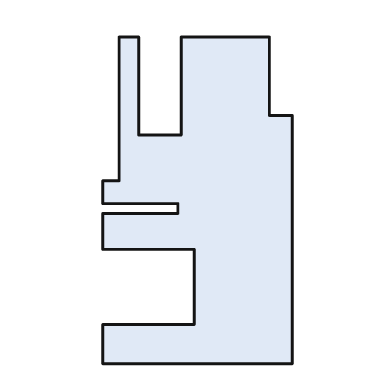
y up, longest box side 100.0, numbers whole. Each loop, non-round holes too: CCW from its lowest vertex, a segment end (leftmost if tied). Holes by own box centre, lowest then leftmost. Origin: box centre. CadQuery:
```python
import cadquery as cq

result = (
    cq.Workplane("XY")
    .moveTo(-29.0, -50.0)
    .lineTo(29.0, -50.0)
    .lineTo(29.0, 26.0)
    .lineTo(22.0, 26.0)
    .lineTo(22.0, 50.0)
    .lineTo(-5.0, 50.0)
    .lineTo(-5.0, 20.0)
    .lineTo(-18.0, 20.0)
    .lineTo(-18.0, 50.0)
    .lineTo(-24.0, 50.0)
    .lineTo(-24.0, 6.0)
    .lineTo(-29.0, 6.0)
    .lineTo(-29.0, -1.0)
    .lineTo(-6.0, -1.0)
    .lineTo(-6.0, -4.0)
    .lineTo(-29.0, -4.0)
    .lineTo(-29.0, -15.0)
    .lineTo(-1.0, -15.0)
    .lineTo(-1.0, -38.0)
    .lineTo(-29.0, -38.0)
    .close()
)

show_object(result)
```